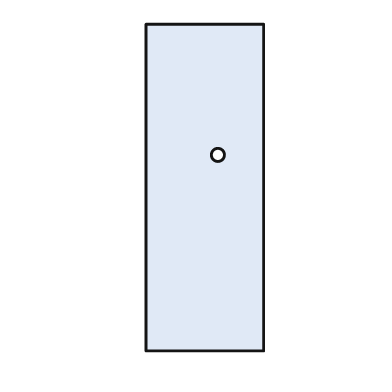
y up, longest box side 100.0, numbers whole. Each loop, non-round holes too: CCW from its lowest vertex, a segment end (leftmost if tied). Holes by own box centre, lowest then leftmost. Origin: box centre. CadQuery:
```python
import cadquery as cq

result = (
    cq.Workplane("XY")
    .moveTo(-18.0, -50.0)
    .lineTo(18.0, -50.0)
    .lineTo(18.0, 50.0)
    .lineTo(-18.0, 50.0)
    .close()
    .moveTo(4.0, 10.0)
    .circle(2.0)
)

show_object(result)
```